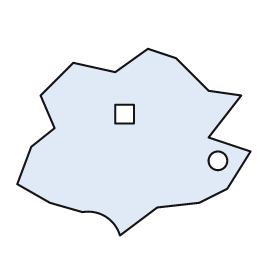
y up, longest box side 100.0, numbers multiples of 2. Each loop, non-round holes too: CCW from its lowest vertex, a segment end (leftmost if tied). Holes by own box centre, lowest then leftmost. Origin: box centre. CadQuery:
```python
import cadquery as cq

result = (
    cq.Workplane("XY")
    .moveTo(-6.0, -40.0)
    .lineTo(10.0, -28.0)
    .lineTo(28.0, -26.0)
    .lineTo(40.0, -20.0)
    .lineTo(50.0, -4.0)
    .lineTo(32.0, 2.0)
    .lineTo(46.0, 20.0)
    .lineTo(32.0, 22.0)
    .lineTo(18.0, 36.0)
    .lineTo(6.0, 40.0)
    .lineTo(-8.0, 30.0)
    .lineTo(-26.0, 34.0)
    .lineTo(-40.0, 20.0)
    .lineTo(-34.0, 6.0)
    .lineTo(-44.0, -2.0)
    .lineTo(-50.0, -18.0)
    .lineTo(-36.0, -26.0)
    .lineTo(-22.0, -30.0)
    .threePointArc((-12.0, -32.0), (-6.0, -40.0))
    .close()
    .moveTo(36.0, -8.0)
    .circle(4.0)
    .moveTo(-8.0, 8.0)
    .lineTo(0.0, 8.0)
    .lineTo(0.0, 16.0)
    .lineTo(-8.0, 16.0)
    .close()
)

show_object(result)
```